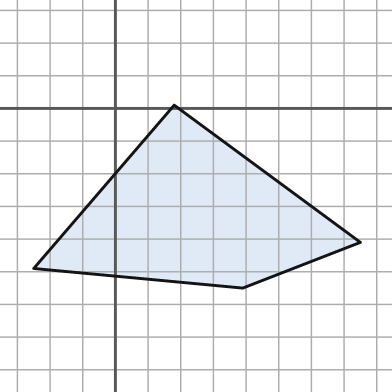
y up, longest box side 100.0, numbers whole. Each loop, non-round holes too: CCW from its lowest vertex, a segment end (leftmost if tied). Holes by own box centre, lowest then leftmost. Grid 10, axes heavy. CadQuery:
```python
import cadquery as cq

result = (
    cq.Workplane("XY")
    .moveTo(39.0, -55.0)
    .lineTo(75.0, -41.0)
    .lineTo(18.0, 1.0)
    .lineTo(-25.0, -49.0)
    .close()
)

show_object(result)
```